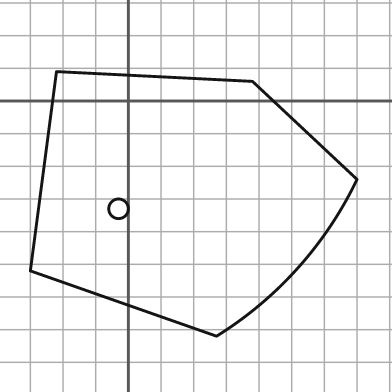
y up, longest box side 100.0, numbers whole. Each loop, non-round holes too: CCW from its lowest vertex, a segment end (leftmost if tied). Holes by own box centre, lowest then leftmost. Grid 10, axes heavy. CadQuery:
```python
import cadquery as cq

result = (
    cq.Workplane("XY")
    .moveTo(27.0, -72.0)
    .threePointArc((52.0, -51.0), (70.0, -24.0))
    .lineTo(38.0, 6.0)
    .lineTo(-22.0, 9.0)
    .lineTo(-30.0, -52.0)
    .close()
    .moveTo(-3.0, -33.0)
    .circle(3.0)
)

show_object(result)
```